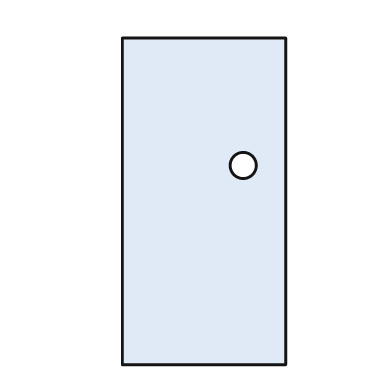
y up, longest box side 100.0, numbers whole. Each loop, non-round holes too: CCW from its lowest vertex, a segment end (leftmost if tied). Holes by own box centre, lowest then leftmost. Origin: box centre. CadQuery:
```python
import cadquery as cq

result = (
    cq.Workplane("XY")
    .moveTo(-25.0, -50.0)
    .lineTo(25.0, -50.0)
    .lineTo(25.0, 50.0)
    .lineTo(-25.0, 50.0)
    .close()
    .moveTo(12.0, 11.0)
    .circle(4.0)
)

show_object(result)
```